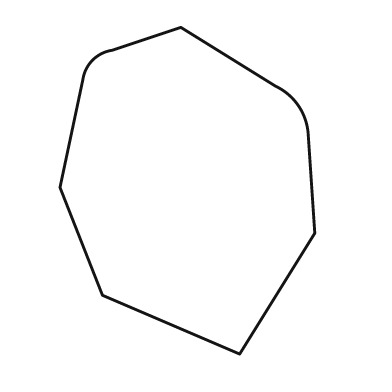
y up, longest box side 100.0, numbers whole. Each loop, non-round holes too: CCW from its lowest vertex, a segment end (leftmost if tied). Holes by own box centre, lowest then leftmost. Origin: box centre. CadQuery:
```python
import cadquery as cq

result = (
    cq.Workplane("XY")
    .moveTo(16.0, -50.0)
    .lineTo(39.0, -13.0)
    .lineTo(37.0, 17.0)
    .threePointArc((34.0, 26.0), (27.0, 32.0))
    .lineTo(-2.0, 50.0)
    .lineTo(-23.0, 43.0)
    .threePointArc((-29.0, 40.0), (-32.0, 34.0))
    .lineTo(-39.0, 1.0)
    .lineTo(-26.0, -32.0)
    .close()
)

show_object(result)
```